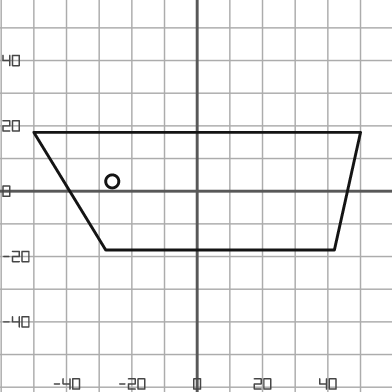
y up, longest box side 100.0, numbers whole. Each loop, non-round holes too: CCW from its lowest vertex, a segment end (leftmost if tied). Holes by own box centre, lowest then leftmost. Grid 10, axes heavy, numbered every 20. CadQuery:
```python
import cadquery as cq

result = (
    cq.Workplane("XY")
    .moveTo(-28.0, -18.0)
    .lineTo(42.0, -18.0)
    .lineTo(50.0, 18.0)
    .lineTo(-50.0, 18.0)
    .close()
    .moveTo(-26.0, 3.0)
    .circle(2.0)
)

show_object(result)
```